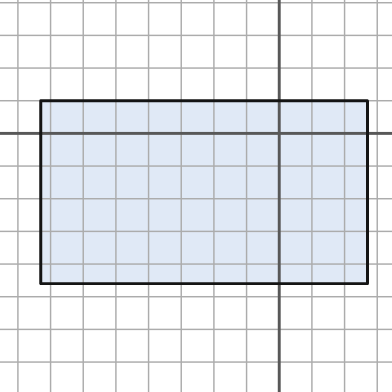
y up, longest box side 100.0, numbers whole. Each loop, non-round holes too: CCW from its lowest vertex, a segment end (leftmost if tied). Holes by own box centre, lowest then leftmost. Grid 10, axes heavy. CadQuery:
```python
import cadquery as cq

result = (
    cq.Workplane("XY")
    .moveTo(-73.0, -46.0)
    .lineTo(27.0, -46.0)
    .lineTo(27.0, 10.0)
    .lineTo(-73.0, 10.0)
    .close()
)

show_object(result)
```